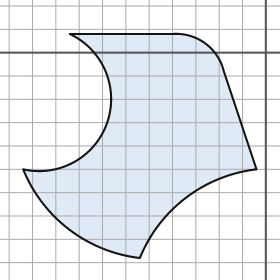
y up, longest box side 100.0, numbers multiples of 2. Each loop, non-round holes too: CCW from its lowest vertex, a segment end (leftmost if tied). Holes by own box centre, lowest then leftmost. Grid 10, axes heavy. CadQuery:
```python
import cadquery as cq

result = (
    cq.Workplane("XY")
    .moveTo(-54.0, -88.0)
    .threePointArc((-34.0, -62.0), (-4.0, -50.0))
    .lineTo(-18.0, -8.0)
    .threePointArc((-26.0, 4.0), (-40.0, 8.0))
    .lineTo(-84.0, 8.0)
    .threePointArc((-68.0, -30.0), (-104.0, -50.0))
    .threePointArc((-84.0, -76.0), (-54.0, -88.0))
    .close()
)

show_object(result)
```